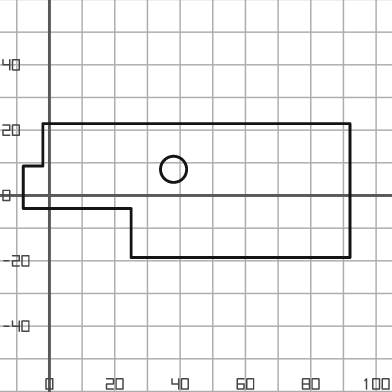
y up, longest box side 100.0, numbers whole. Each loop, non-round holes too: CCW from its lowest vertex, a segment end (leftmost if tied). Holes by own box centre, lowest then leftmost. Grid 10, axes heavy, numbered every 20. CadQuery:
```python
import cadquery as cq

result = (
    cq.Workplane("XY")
    .moveTo(25.0, -19.0)
    .lineTo(92.0, -19.0)
    .lineTo(92.0, 22.0)
    .lineTo(-2.0, 22.0)
    .lineTo(-2.0, 9.0)
    .lineTo(-8.0, 9.0)
    .lineTo(-8.0, -4.0)
    .lineTo(25.0, -4.0)
    .close()
    .moveTo(38.0, 8.0)
    .circle(4.0)
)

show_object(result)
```